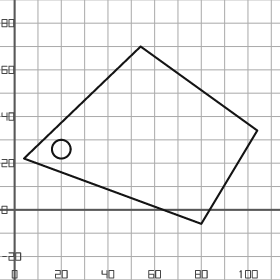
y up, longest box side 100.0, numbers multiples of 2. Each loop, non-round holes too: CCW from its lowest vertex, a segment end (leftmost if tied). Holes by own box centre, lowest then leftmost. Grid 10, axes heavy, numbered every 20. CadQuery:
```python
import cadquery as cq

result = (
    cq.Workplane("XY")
    .moveTo(80.0, -6.0)
    .lineTo(104.0, 34.0)
    .lineTo(54.0, 70.0)
    .lineTo(4.0, 22.0)
    .close()
    .moveTo(20.0, 26.0)
    .circle(4.0)
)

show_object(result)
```